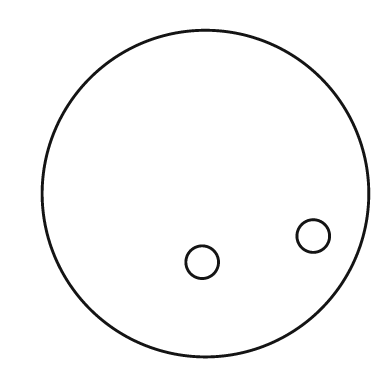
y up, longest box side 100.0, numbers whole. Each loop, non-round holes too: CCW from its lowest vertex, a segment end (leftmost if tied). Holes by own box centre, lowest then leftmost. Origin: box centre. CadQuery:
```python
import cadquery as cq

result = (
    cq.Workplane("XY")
    .moveTo(0.0, 0.0)
    .circle(50.0)
    .moveTo(-1.0, -21.0)
    .circle(5.0)
    .moveTo(33.0, -13.0)
    .circle(5.0)
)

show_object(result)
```